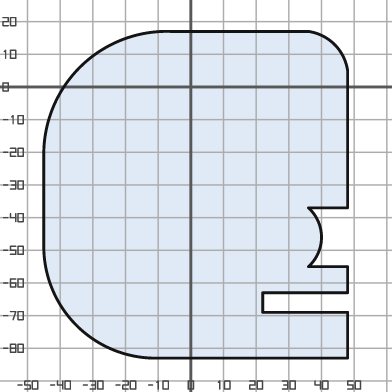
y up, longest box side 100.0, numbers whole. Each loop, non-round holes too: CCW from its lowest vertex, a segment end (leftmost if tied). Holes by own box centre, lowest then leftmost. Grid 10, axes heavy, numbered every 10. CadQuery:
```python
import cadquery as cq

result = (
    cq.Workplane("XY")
    .moveTo(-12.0, -83.0)
    .lineTo(48.0, -83.0)
    .lineTo(48.0, -69.0)
    .lineTo(22.0, -69.0)
    .lineTo(22.0, -63.0)
    .lineTo(48.0, -63.0)
    .lineTo(48.0, -55.0)
    .lineTo(36.0, -55.0)
    .threePointArc((40.0, -46.0), (36.0, -37.0))
    .lineTo(48.0, -37.0)
    .lineTo(48.0, 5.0)
    .threePointArc((44.0, 13.0), (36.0, 17.0))
    .lineTo(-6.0, 17.0)
    .threePointArc((-34.0, 6.0), (-45.0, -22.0))
    .lineTo(-45.0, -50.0)
    .threePointArc((-35.0, -73.0), (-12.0, -83.0))
    .close()
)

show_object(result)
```